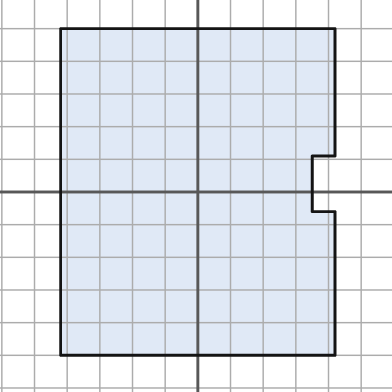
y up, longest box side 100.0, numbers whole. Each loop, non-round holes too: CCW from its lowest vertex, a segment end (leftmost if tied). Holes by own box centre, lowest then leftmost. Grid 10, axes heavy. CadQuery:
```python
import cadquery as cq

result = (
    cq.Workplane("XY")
    .moveTo(-42.0, -50.0)
    .lineTo(42.0, -50.0)
    .lineTo(42.0, -6.0)
    .lineTo(35.0, -6.0)
    .lineTo(35.0, 11.0)
    .lineTo(42.0, 11.0)
    .lineTo(42.0, 50.0)
    .lineTo(-42.0, 50.0)
    .close()
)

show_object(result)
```